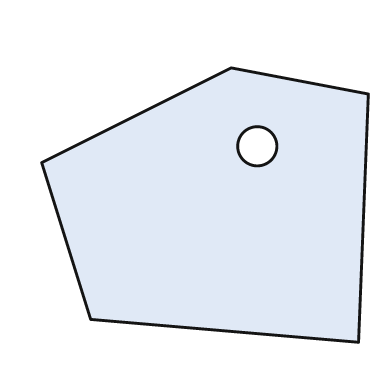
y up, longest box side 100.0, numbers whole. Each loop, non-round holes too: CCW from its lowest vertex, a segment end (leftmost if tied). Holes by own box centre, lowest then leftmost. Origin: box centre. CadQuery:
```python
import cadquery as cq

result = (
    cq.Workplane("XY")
    .moveTo(47.0, -42.0)
    .lineTo(50.0, 34.0)
    .lineTo(8.0, 42.0)
    .lineTo(-50.0, 13.0)
    .lineTo(-35.0, -35.0)
    .close()
    .moveTo(16.0, 18.0)
    .circle(6.0)
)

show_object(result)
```